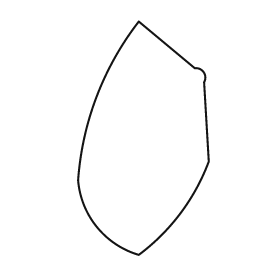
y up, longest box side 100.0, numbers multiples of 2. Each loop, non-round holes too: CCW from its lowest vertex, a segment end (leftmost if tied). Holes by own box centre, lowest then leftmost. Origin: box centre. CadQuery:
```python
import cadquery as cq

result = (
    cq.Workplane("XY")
    .moveTo(-2.0, -50.0)
    .threePointArc((16.0, -32.0), (28.0, -10.0))
    .lineTo(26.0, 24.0)
    .threePointArc((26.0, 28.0), (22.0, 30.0))
    .lineTo(-2.0, 50.0)
    .threePointArc((-20.0, 18.0), (-28.0, -18.0))
    .threePointArc((-20.0, -38.0), (-2.0, -50.0))
    .close()
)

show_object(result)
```